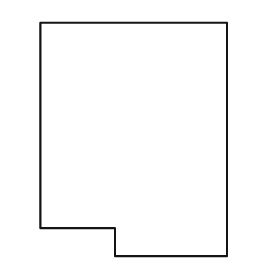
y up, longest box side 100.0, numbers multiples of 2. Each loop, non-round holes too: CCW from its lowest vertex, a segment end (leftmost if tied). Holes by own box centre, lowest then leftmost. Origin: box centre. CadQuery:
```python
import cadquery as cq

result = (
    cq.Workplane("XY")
    .moveTo(-8.0, -50.0)
    .lineTo(40.0, -50.0)
    .lineTo(40.0, 50.0)
    .lineTo(-40.0, 50.0)
    .lineTo(-40.0, -38.0)
    .lineTo(-8.0, -38.0)
    .close()
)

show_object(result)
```